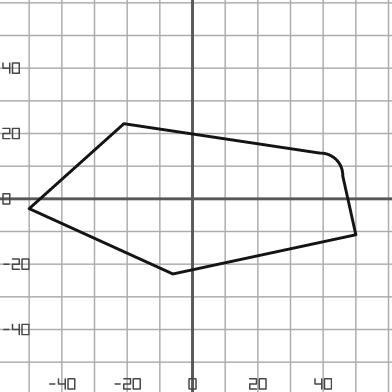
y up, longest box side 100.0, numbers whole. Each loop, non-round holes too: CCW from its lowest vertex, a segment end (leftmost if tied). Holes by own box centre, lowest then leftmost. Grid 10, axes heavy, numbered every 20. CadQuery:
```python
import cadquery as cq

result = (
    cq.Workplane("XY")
    .moveTo(-6.0, -23.0)
    .lineTo(50.0, -11.0)
    .lineTo(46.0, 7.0)
    .threePointArc((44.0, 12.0), (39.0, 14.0))
    .lineTo(-21.0, 23.0)
    .lineTo(-50.0, -3.0)
    .close()
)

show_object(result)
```